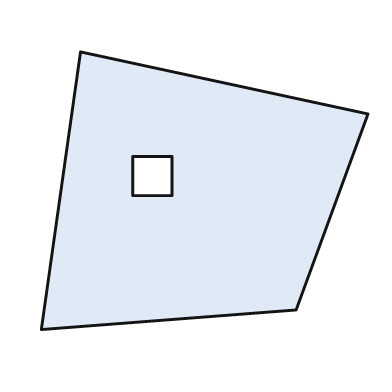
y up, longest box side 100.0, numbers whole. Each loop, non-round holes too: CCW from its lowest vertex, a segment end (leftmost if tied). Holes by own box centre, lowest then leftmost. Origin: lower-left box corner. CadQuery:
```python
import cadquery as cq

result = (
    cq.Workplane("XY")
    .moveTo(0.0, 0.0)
    .lineTo(78.0, 6.0)
    .lineTo(100.0, 66.0)
    .lineTo(12.0, 85.0)
    .close()
    .moveTo(28.0, 41.0)
    .lineTo(40.0, 41.0)
    .lineTo(40.0, 53.0)
    .lineTo(28.0, 53.0)
    .close()
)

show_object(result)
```